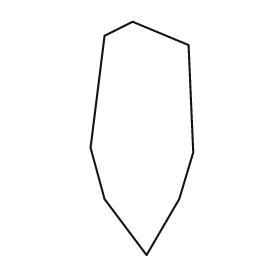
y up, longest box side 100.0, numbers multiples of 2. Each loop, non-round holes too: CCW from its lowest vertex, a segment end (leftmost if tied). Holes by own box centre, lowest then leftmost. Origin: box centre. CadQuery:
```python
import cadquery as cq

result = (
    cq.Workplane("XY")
    .moveTo(2.0, -50.0)
    .lineTo(16.0, -26.0)
    .lineTo(22.0, -6.0)
    .lineTo(20.0, 40.0)
    .lineTo(-4.0, 50.0)
    .lineTo(-16.0, 44.0)
    .lineTo(-22.0, -4.0)
    .lineTo(-16.0, -26.0)
    .close()
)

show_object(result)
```